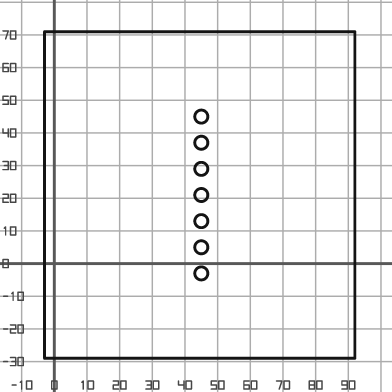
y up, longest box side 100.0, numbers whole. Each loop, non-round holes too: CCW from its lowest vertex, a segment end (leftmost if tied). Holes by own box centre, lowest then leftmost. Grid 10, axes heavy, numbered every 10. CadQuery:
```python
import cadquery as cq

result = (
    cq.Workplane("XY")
    .moveTo(-3.0, -29.0)
    .lineTo(92.0, -29.0)
    .lineTo(92.0, 71.0)
    .lineTo(-3.0, 71.0)
    .close()
    .moveTo(45.0, -3.0)
    .circle(2.0)
    .moveTo(45.0, 5.0)
    .circle(2.0)
    .moveTo(45.0, 13.0)
    .circle(2.0)
    .moveTo(45.0, 21.0)
    .circle(2.0)
    .moveTo(45.0, 29.0)
    .circle(2.0)
    .moveTo(45.0, 37.0)
    .circle(2.0)
    .moveTo(45.0, 45.0)
    .circle(2.0)
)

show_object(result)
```